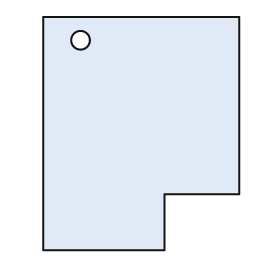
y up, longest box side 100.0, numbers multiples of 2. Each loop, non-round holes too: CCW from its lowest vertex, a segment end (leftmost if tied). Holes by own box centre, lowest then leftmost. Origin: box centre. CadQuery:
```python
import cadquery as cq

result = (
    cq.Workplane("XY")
    .moveTo(-42.0, -50.0)
    .lineTo(10.0, -50.0)
    .lineTo(10.0, -26.0)
    .lineTo(42.0, -26.0)
    .lineTo(42.0, 50.0)
    .lineTo(-42.0, 50.0)
    .close()
    .moveTo(-26.0, 40.0)
    .circle(4.0)
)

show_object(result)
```